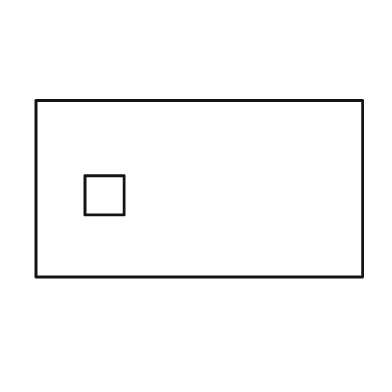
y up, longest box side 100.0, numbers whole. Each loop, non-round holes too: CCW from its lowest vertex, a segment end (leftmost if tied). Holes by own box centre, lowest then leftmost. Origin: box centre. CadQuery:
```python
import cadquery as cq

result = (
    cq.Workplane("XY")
    .moveTo(-50.0, -27.0)
    .lineTo(50.0, -27.0)
    .lineTo(50.0, 27.0)
    .lineTo(-50.0, 27.0)
    .close()
    .moveTo(-35.0, -8.0)
    .lineTo(-23.0, -8.0)
    .lineTo(-23.0, 4.0)
    .lineTo(-35.0, 4.0)
    .close()
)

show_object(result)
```